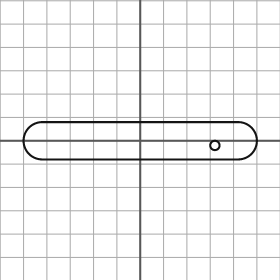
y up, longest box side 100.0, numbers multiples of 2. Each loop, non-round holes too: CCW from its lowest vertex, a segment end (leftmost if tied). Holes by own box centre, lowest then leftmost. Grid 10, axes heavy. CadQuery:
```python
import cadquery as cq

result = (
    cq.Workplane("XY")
    .moveTo(-42.0, -8.0)
    .lineTo(42.0, -8.0)
    .threePointArc((50.0, 0.0), (42.0, 8.0))
    .lineTo(-42.0, 8.0)
    .threePointArc((-50.0, 0.0), (-42.0, -8.0))
    .close()
    .moveTo(32.0, -2.0)
    .circle(2.0)
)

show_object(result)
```